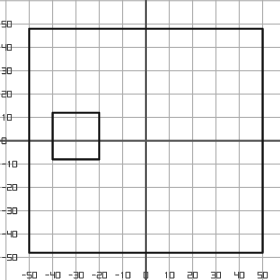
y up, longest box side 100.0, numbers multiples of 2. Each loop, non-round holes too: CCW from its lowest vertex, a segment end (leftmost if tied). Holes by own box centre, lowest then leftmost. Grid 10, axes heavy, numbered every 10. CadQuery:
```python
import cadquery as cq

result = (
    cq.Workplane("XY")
    .moveTo(-50.0, -48.0)
    .lineTo(50.0, -48.0)
    .lineTo(50.0, 48.0)
    .lineTo(-50.0, 48.0)
    .close()
    .moveTo(-40.0, -8.0)
    .lineTo(-20.0, -8.0)
    .lineTo(-20.0, 12.0)
    .lineTo(-40.0, 12.0)
    .close()
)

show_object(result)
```